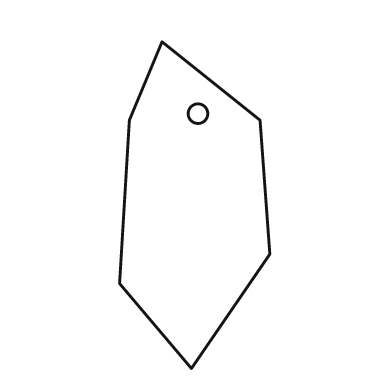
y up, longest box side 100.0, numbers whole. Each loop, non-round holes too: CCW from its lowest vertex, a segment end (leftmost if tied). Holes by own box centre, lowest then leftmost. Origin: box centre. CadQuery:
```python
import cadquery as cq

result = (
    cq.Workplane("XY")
    .moveTo(-1.0, -50.0)
    .lineTo(23.0, -15.0)
    .lineTo(20.0, 26.0)
    .lineTo(-10.0, 50.0)
    .lineTo(-20.0, 26.0)
    .lineTo(-23.0, -24.0)
    .close()
    .moveTo(1.0, 28.0)
    .circle(3.0)
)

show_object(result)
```